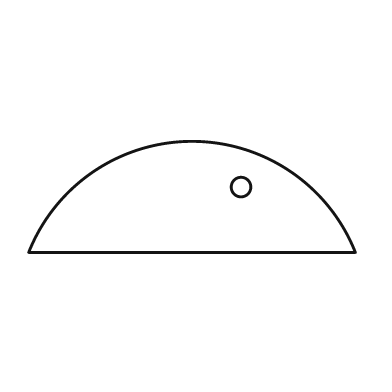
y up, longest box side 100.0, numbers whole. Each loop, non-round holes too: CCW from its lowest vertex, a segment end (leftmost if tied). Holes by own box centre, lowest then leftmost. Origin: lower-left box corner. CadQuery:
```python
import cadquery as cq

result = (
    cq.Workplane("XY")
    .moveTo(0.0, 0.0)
    .lineTo(100.0, 0.0)
    .threePointArc((50.0, 34.0), (0.0, 0.0))
    .close()
    .moveTo(65.0, 20.0)
    .circle(3.0)
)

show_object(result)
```